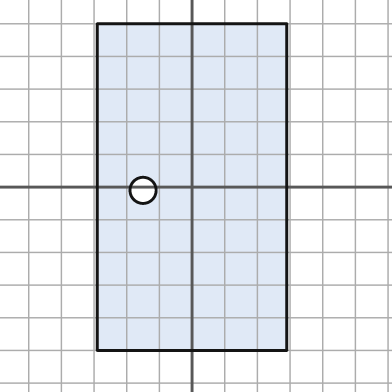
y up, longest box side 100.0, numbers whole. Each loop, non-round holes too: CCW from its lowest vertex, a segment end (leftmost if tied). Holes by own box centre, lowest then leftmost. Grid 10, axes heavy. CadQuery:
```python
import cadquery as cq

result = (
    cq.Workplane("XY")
    .moveTo(-29.0, -50.0)
    .lineTo(29.0, -50.0)
    .lineTo(29.0, 50.0)
    .lineTo(-29.0, 50.0)
    .close()
    .moveTo(-15.0, -1.0)
    .circle(4.0)
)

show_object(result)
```